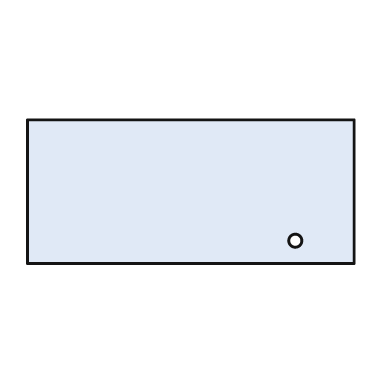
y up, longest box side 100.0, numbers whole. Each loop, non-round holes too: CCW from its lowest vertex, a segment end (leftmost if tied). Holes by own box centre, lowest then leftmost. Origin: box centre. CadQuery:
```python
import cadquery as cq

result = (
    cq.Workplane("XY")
    .moveTo(-50.0, -22.0)
    .lineTo(50.0, -22.0)
    .lineTo(50.0, 22.0)
    .lineTo(-50.0, 22.0)
    .close()
    .moveTo(32.0, -15.0)
    .circle(2.0)
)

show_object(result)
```